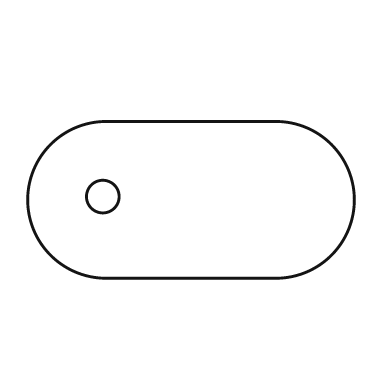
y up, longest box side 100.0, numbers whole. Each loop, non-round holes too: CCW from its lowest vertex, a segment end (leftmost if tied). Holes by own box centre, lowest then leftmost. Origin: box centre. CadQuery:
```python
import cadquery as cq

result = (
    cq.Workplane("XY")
    .moveTo(-26.0, -24.0)
    .lineTo(26.0, -24.0)
    .threePointArc((50.0, 0.0), (26.0, 24.0))
    .lineTo(-26.0, 24.0)
    .threePointArc((-50.0, 0.0), (-26.0, -24.0))
    .close()
    .moveTo(-27.0, 1.0)
    .circle(5.0)
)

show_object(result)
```